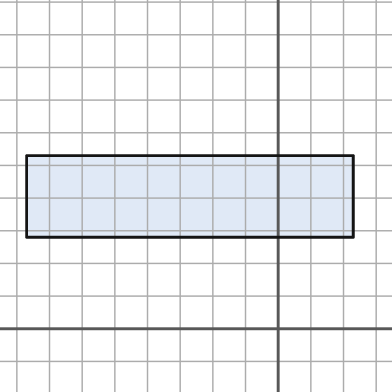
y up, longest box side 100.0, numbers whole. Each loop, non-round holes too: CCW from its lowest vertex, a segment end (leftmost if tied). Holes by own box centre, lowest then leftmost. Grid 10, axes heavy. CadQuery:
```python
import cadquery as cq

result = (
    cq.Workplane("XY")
    .moveTo(-77.0, 28.0)
    .lineTo(23.0, 28.0)
    .lineTo(23.0, 53.0)
    .lineTo(-77.0, 53.0)
    .close()
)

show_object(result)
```